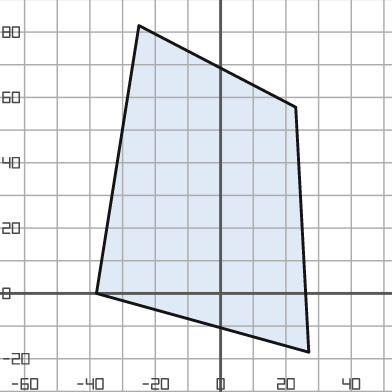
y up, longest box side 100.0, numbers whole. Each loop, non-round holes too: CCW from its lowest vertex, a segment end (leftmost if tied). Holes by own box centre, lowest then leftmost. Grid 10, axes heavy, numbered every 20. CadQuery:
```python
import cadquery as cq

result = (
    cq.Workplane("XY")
    .moveTo(27.0, -18.0)
    .lineTo(23.0, 57.0)
    .lineTo(-25.0, 82.0)
    .lineTo(-38.0, 0.0)
    .close()
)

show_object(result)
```